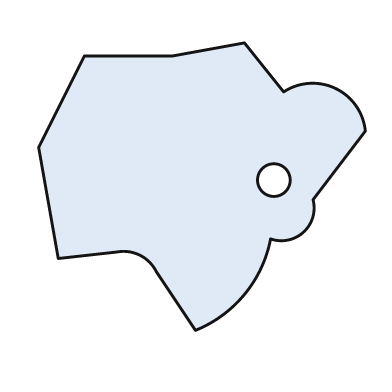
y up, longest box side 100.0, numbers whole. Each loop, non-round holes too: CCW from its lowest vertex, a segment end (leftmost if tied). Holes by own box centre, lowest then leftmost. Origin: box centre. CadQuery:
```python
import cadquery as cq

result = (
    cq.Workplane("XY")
    .moveTo(-2.0, -44.0)
    .threePointArc((13.0, -33.0), (21.0, -16.0))
    .threePointArc((31.0, -14.0), (34.0, -4.0))
    .lineTo(50.0, 17.0)
    .threePointArc((41.0, 30.0), (25.0, 29.0))
    .lineTo(13.0, 44.0)
    .lineTo(-9.0, 40.0)
    .lineTo(-36.0, 40.0)
    .lineTo(-50.0, 12.0)
    .lineTo(-44.0, -22.0)
    .lineTo(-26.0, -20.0)
    .threePointArc((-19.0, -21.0), (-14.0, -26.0))
    .close()
    .moveTo(22.0, 2.0)
    .circle(5.0)
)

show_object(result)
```